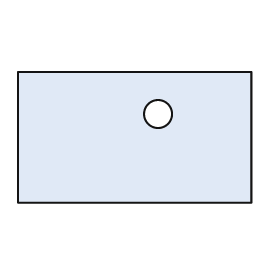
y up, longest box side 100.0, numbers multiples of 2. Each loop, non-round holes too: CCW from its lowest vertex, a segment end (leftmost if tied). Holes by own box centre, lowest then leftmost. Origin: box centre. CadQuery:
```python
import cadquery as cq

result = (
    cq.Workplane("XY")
    .moveTo(-50.0, -28.0)
    .lineTo(50.0, -28.0)
    .lineTo(50.0, 28.0)
    .lineTo(-50.0, 28.0)
    .close()
    .moveTo(10.0, 10.0)
    .circle(6.0)
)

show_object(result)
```